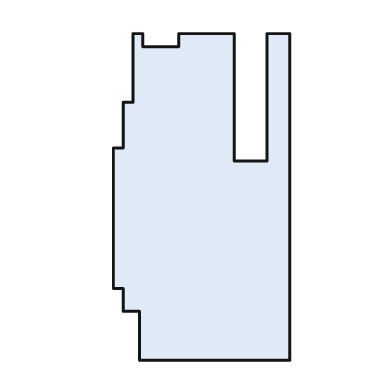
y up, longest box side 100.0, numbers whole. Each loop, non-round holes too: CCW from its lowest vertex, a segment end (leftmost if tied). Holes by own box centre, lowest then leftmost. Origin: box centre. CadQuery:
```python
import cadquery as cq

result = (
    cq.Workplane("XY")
    .moveTo(-19.0, -50.0)
    .lineTo(27.0, -50.0)
    .lineTo(27.0, 50.0)
    .lineTo(20.0, 50.0)
    .lineTo(20.0, 11.0)
    .lineTo(10.0, 11.0)
    .lineTo(10.0, 50.0)
    .lineTo(-7.0, 50.0)
    .lineTo(-7.0, 46.0)
    .lineTo(-18.0, 46.0)
    .lineTo(-18.0, 50.0)
    .lineTo(-21.0, 50.0)
    .lineTo(-21.0, 29.0)
    .lineTo(-24.0, 29.0)
    .lineTo(-24.0, 15.0)
    .lineTo(-27.0, 15.0)
    .lineTo(-27.0, -28.0)
    .lineTo(-24.0, -28.0)
    .lineTo(-24.0, -35.0)
    .lineTo(-19.0, -35.0)
    .close()
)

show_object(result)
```